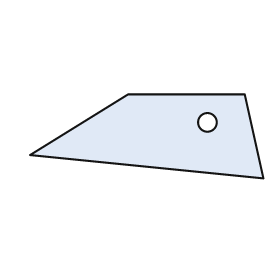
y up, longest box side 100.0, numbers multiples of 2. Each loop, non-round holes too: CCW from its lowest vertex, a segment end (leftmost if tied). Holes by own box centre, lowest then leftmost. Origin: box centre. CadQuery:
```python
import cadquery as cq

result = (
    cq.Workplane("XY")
    .moveTo(50.0, -18.0)
    .lineTo(42.0, 18.0)
    .lineTo(-8.0, 18.0)
    .lineTo(-50.0, -8.0)
    .close()
    .moveTo(26.0, 6.0)
    .circle(4.0)
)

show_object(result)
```